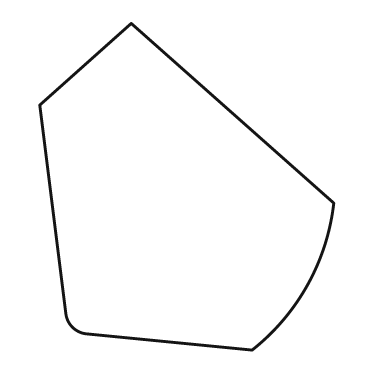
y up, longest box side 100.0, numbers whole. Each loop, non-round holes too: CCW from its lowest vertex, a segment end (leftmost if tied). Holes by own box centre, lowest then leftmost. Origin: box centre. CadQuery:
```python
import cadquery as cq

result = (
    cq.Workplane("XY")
    .moveTo(20.0, -50.0)
    .threePointArc((37.0, -30.0), (45.0, -5.0))
    .lineTo(-17.0, 50.0)
    .lineTo(-45.0, 25.0)
    .lineTo(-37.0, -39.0)
    .threePointArc((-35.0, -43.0), (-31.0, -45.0))
    .close()
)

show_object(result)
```